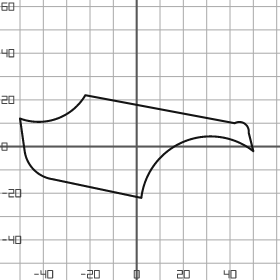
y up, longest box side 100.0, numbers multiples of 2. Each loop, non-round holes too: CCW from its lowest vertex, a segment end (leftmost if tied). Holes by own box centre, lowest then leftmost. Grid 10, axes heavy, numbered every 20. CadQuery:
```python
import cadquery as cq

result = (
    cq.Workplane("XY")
    .moveTo(2.0, -22.0)
    .threePointArc((20.0, 2.0), (50.0, -2.0))
    .lineTo(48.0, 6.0)
    .threePointArc((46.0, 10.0), (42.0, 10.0))
    .lineTo(-22.0, 22.0)
    .threePointArc((-34.0, 12.0), (-50.0, 12.0))
    .lineTo(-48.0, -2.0)
    .threePointArc((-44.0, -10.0), (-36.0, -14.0))
    .close()
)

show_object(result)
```